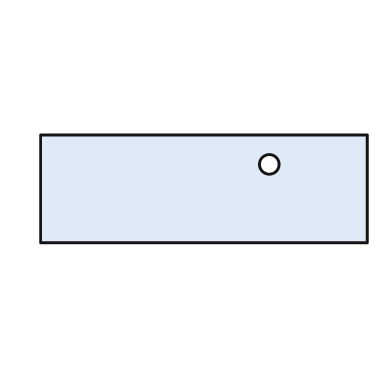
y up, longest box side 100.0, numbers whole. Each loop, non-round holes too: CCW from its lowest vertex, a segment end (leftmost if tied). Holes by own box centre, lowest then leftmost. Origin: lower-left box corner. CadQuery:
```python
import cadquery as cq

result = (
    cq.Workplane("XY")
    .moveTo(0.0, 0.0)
    .lineTo(100.0, 0.0)
    .lineTo(100.0, 33.0)
    .lineTo(0.0, 33.0)
    .close()
    .moveTo(70.0, 24.0)
    .circle(3.0)
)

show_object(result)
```